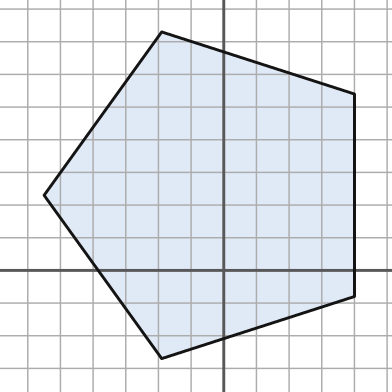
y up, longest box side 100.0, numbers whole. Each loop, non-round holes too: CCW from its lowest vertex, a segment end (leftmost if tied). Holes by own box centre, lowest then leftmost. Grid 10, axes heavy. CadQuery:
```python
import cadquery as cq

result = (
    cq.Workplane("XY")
    .moveTo(-19.0, -27.0)
    .lineTo(40.0, -8.0)
    .lineTo(40.0, 54.0)
    .lineTo(-19.0, 73.0)
    .lineTo(-55.0, 23.0)
    .close()
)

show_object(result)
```